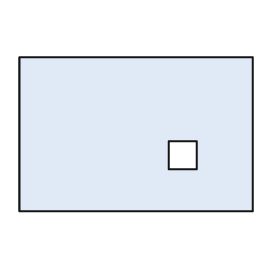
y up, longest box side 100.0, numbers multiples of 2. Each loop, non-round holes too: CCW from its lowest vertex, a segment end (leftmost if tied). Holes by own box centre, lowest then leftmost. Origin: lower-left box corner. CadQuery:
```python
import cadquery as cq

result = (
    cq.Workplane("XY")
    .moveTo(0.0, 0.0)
    .lineTo(100.0, 0.0)
    .lineTo(100.0, 66.0)
    .lineTo(0.0, 66.0)
    .close()
    .moveTo(64.0, 18.0)
    .lineTo(76.0, 18.0)
    .lineTo(76.0, 30.0)
    .lineTo(64.0, 30.0)
    .close()
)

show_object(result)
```